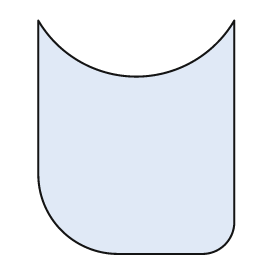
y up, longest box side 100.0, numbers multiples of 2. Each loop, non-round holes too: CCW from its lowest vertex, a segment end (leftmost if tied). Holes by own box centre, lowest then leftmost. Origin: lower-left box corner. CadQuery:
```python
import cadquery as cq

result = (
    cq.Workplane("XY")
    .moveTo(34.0, 0.0)
    .lineTo(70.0, 0.0)
    .threePointArc((80.0, 4.0), (84.0, 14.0))
    .lineTo(84.0, 100.0)
    .threePointArc((42.0, 76.0), (0.0, 100.0))
    .lineTo(0.0, 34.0)
    .threePointArc((10.0, 10.0), (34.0, 0.0))
    .close()
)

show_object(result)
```